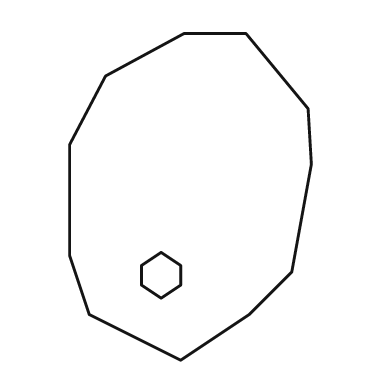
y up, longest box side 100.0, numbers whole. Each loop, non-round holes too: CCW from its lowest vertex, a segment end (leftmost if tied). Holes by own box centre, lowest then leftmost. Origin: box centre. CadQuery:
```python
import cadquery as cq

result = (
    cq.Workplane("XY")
    .moveTo(-3.0, -50.0)
    .lineTo(18.0, -36.0)
    .lineTo(31.0, -23.0)
    .lineTo(37.0, 10.0)
    .lineTo(36.0, 27.0)
    .lineTo(17.0, 50.0)
    .lineTo(-2.0, 50.0)
    .lineTo(-26.0, 37.0)
    .lineTo(-37.0, 16.0)
    .lineTo(-37.0, -18.0)
    .lineTo(-31.0, -36.0)
    .close()
    .moveTo(-9.0, -31.0)
    .lineTo(-3.0, -27.0)
    .lineTo(-3.0, -21.0)
    .lineTo(-9.0, -17.0)
    .lineTo(-15.0, -21.0)
    .lineTo(-15.0, -27.0)
    .close()
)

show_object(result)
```